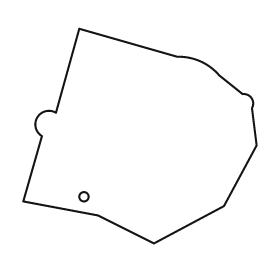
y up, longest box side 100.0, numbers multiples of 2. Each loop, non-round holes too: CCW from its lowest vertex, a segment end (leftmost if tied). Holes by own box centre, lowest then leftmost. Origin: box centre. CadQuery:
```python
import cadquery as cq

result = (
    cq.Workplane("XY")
    .moveTo(6.0, -46.0)
    .lineTo(36.0, -30.0)
    .lineTo(50.0, -4.0)
    .lineTo(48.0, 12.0)
    .threePointArc((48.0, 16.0), (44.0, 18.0))
    .lineTo(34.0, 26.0)
    .threePointArc((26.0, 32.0), (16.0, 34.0))
    .lineTo(-26.0, 46.0)
    .lineTo(-36.0, 10.0)
    .threePointArc((-44.0, 8.0), (-42.0, 0.0))
    .lineTo(-50.0, -28.0)
    .lineTo(-18.0, -34.0)
    .close()
    .moveTo(-24.0, -26.0)
    .circle(2.0)
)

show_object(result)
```